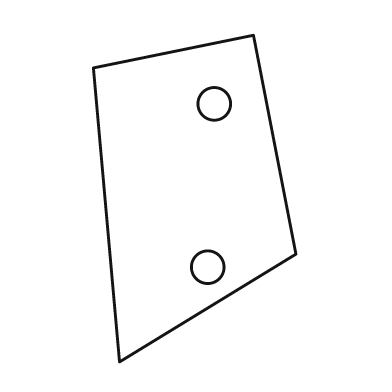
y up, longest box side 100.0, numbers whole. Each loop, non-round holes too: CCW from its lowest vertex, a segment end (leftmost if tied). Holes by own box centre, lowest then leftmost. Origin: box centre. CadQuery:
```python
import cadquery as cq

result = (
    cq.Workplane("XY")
    .moveTo(-23.0, -50.0)
    .lineTo(31.0, -17.0)
    .lineTo(18.0, 50.0)
    .lineTo(-31.0, 40.0)
    .close()
    .moveTo(4.0, -21.0)
    .circle(5.0)
    .moveTo(6.0, 29.0)
    .circle(5.0)
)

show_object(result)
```